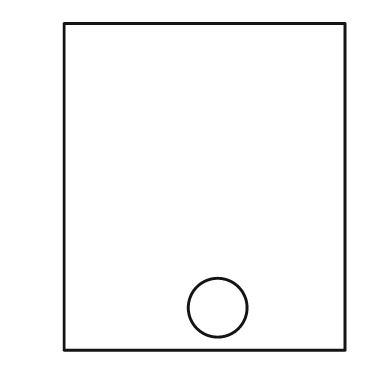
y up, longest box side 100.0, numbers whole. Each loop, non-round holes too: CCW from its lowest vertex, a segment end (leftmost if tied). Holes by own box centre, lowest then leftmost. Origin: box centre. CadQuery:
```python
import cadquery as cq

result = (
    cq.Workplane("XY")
    .moveTo(-43.0, -50.0)
    .lineTo(43.0, -50.0)
    .lineTo(43.0, 50.0)
    .lineTo(-43.0, 50.0)
    .close()
    .moveTo(4.0, -37.0)
    .circle(9.0)
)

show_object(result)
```